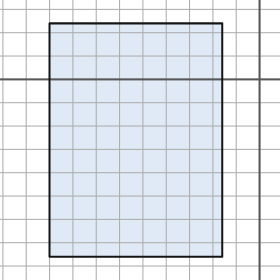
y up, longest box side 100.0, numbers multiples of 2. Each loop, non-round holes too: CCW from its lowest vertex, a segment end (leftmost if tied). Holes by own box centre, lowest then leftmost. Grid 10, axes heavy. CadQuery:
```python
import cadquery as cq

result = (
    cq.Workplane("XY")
    .moveTo(-90.0, -76.0)
    .lineTo(-16.0, -76.0)
    .lineTo(-16.0, 24.0)
    .lineTo(-90.0, 24.0)
    .close()
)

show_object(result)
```